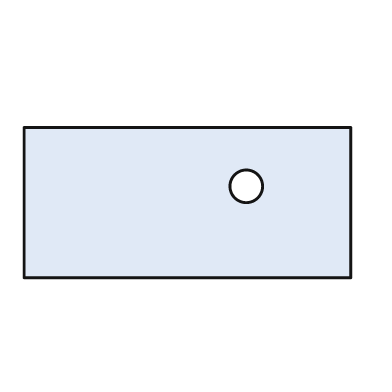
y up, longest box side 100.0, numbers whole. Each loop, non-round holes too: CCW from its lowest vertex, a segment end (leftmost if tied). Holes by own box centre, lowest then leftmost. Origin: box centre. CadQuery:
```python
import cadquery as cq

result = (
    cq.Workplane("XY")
    .moveTo(-50.0, -23.0)
    .lineTo(50.0, -23.0)
    .lineTo(50.0, 23.0)
    .lineTo(-50.0, 23.0)
    .close()
    .moveTo(18.0, 5.0)
    .circle(5.0)
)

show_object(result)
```